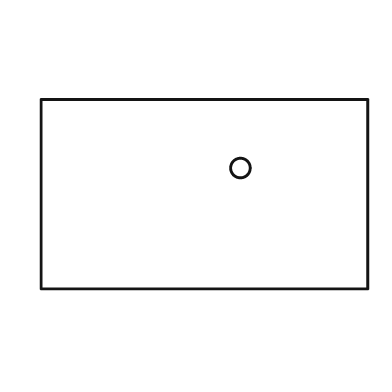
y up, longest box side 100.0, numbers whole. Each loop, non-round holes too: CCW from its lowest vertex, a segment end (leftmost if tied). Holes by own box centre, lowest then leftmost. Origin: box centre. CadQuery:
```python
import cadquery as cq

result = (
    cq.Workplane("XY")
    .moveTo(-50.0, -29.0)
    .lineTo(50.0, -29.0)
    .lineTo(50.0, 29.0)
    .lineTo(-50.0, 29.0)
    .close()
    .moveTo(11.0, 8.0)
    .circle(3.0)
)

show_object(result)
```